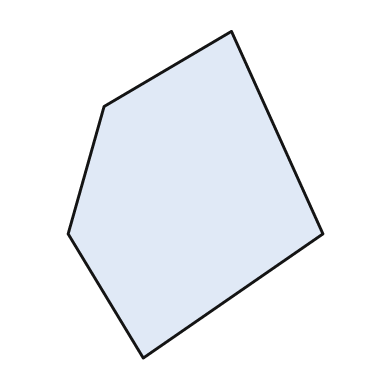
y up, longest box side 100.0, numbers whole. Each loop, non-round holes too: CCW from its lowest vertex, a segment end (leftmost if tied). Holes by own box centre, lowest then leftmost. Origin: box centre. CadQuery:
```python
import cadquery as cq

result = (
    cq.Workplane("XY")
    .moveTo(-16.0, -50.0)
    .lineTo(39.0, -12.0)
    .lineTo(11.0, 50.0)
    .lineTo(-28.0, 27.0)
    .lineTo(-39.0, -12.0)
    .close()
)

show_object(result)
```